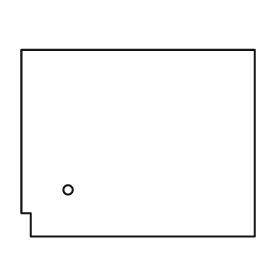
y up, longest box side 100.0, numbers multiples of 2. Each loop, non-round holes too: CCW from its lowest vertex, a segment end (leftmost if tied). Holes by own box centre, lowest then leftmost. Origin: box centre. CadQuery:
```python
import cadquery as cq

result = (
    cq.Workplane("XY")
    .moveTo(-46.0, -40.0)
    .lineTo(50.0, -40.0)
    .lineTo(50.0, 40.0)
    .lineTo(-50.0, 40.0)
    .lineTo(-50.0, -30.0)
    .lineTo(-46.0, -30.0)
    .close()
    .moveTo(-30.0, -20.0)
    .circle(2.0)
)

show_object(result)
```